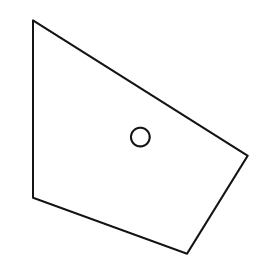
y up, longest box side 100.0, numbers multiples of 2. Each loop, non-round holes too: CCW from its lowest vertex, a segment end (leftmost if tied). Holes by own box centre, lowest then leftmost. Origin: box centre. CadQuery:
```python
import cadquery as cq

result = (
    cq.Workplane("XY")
    .moveTo(20.0, -50.0)
    .lineTo(46.0, -8.0)
    .lineTo(-46.0, 50.0)
    .lineTo(-46.0, -26.0)
    .close()
    .moveTo(0.0, 0.0)
    .circle(4.0)
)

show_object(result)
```